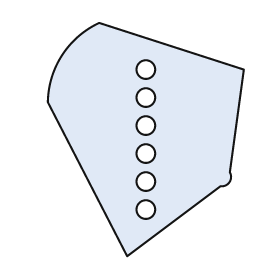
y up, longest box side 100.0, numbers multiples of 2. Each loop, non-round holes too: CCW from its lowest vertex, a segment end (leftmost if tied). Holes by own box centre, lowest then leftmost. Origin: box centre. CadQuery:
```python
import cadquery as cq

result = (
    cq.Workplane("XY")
    .moveTo(-8.0, -50.0)
    .lineTo(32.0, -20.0)
    .threePointArc((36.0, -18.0), (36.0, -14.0))
    .lineTo(42.0, 30.0)
    .lineTo(-20.0, 50.0)
    .threePointArc((-36.0, 36.0), (-42.0, 16.0))
    .close()
    .moveTo(0.0, -30.0)
    .circle(4.0)
    .moveTo(0.0, -18.0)
    .circle(4.0)
    .moveTo(0.0, -6.0)
    .circle(4.0)
    .moveTo(0.0, 6.0)
    .circle(4.0)
    .moveTo(0.0, 18.0)
    .circle(4.0)
    .moveTo(0.0, 30.0)
    .circle(4.0)
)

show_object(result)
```